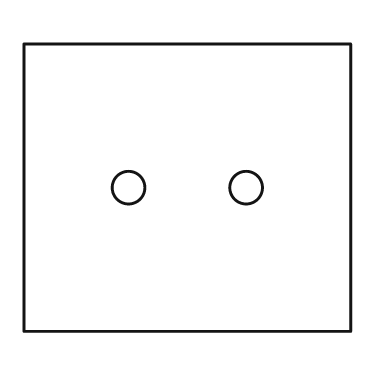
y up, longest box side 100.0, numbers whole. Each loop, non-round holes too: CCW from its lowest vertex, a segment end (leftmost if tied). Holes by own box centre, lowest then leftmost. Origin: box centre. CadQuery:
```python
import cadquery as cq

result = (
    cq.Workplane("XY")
    .moveTo(-50.0, -44.0)
    .lineTo(50.0, -44.0)
    .lineTo(50.0, 44.0)
    .lineTo(-50.0, 44.0)
    .close()
    .moveTo(-18.0, 0.0)
    .circle(5.0)
    .moveTo(18.0, 0.0)
    .circle(5.0)
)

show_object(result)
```